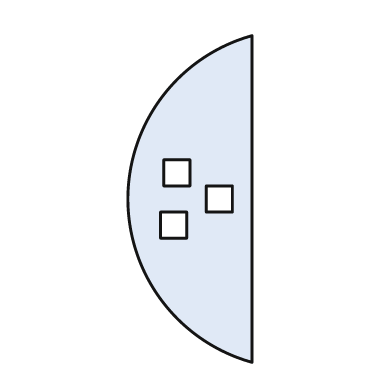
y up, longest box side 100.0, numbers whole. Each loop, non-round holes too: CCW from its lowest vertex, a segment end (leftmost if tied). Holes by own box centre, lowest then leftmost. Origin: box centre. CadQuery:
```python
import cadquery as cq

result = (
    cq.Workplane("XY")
    .moveTo(19.0, -50.0)
    .lineTo(19.0, 50.0)
    .threePointArc((-19.0, 0.0), (19.0, -50.0))
    .close()
    .moveTo(-9.0, -12.0)
    .lineTo(-1.0, -12.0)
    .lineTo(-1.0, -4.0)
    .lineTo(-9.0, -4.0)
    .close()
    .moveTo(5.0, -4.0)
    .lineTo(13.0, -4.0)
    .lineTo(13.0, 4.0)
    .lineTo(5.0, 4.0)
    .close()
    .moveTo(-8.0, 4.0)
    .lineTo(0.0, 4.0)
    .lineTo(0.0, 12.0)
    .lineTo(-8.0, 12.0)
    .close()
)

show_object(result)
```